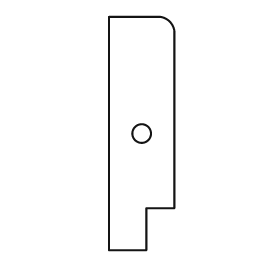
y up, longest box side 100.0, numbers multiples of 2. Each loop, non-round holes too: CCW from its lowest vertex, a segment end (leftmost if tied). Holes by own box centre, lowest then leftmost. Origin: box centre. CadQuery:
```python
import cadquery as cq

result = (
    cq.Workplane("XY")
    .moveTo(-14.0, -50.0)
    .lineTo(2.0, -50.0)
    .lineTo(2.0, -32.0)
    .lineTo(14.0, -32.0)
    .lineTo(14.0, 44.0)
    .threePointArc((12.0, 48.0), (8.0, 50.0))
    .lineTo(-14.0, 50.0)
    .close()
    .moveTo(0.0, 0.0)
    .circle(4.0)
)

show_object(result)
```